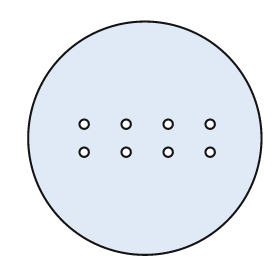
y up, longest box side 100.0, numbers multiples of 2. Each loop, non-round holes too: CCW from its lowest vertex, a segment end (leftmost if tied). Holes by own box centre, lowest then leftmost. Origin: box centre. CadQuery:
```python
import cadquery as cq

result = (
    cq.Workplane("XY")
    .moveTo(0.0, 0.0)
    .circle(50.0)
    .moveTo(-26.0, -6.0)
    .circle(2.0)
    .moveTo(-8.0, -6.0)
    .circle(2.0)
    .moveTo(10.0, -6.0)
    .circle(2.0)
    .moveTo(28.0, -6.0)
    .circle(2.0)
    .moveTo(-26.0, 6.0)
    .circle(2.0)
    .moveTo(-8.0, 6.0)
    .circle(2.0)
    .moveTo(10.0, 6.0)
    .circle(2.0)
    .moveTo(28.0, 6.0)
    .circle(2.0)
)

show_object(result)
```